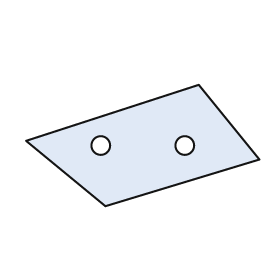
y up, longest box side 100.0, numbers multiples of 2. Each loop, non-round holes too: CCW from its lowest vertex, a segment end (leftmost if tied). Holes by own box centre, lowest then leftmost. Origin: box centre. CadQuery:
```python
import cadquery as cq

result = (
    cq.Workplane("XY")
    .moveTo(-16.0, -26.0)
    .lineTo(50.0, -6.0)
    .lineTo(24.0, 26.0)
    .lineTo(-50.0, 2.0)
    .close()
    .moveTo(-18.0, 0.0)
    .circle(4.0)
    .moveTo(18.0, 0.0)
    .circle(4.0)
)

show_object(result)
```